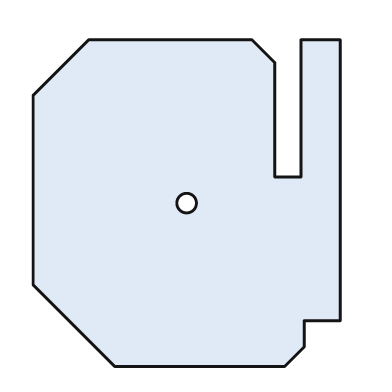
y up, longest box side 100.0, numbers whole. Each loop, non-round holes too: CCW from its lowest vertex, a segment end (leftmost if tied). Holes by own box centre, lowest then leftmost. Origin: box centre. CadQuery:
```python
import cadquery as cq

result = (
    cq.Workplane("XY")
    .moveTo(-22.0, -50.0)
    .lineTo(30.0, -50.0)
    .lineTo(36.0, -44.0)
    .lineTo(36.0, -36.0)
    .lineTo(47.0, -36.0)
    .lineTo(47.0, 50.0)
    .lineTo(35.0, 50.0)
    .lineTo(35.0, 8.0)
    .lineTo(27.0, 8.0)
    .lineTo(27.0, 43.0)
    .lineTo(20.0, 50.0)
    .lineTo(-30.0, 50.0)
    .lineTo(-47.0, 33.0)
    .lineTo(-47.0, -25.0)
    .close()
    .moveTo(0.0, 0.0)
    .circle(3.0)
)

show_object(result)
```